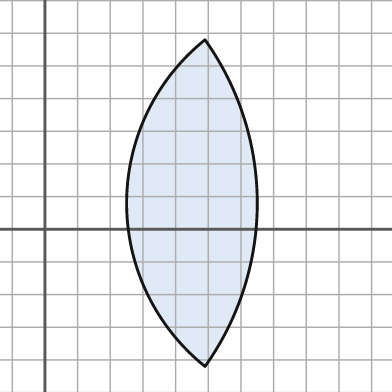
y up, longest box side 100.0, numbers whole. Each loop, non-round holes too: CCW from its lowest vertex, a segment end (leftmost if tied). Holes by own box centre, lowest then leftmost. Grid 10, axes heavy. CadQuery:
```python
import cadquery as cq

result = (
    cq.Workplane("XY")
    .moveTo(49.0, -42.0)
    .threePointArc((65.0, 8.0), (49.0, 58.0))
    .threePointArc((25.0, 8.0), (49.0, -42.0))
    .close()
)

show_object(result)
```